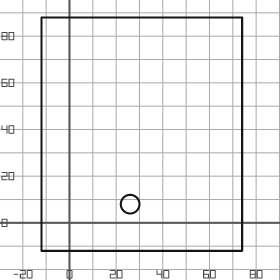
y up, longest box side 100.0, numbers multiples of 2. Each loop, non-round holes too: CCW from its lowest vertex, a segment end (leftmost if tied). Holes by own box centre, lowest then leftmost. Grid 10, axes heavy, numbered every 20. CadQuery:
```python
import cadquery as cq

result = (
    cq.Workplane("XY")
    .moveTo(-12.0, -12.0)
    .lineTo(74.0, -12.0)
    .lineTo(74.0, 88.0)
    .lineTo(-12.0, 88.0)
    .close()
    .moveTo(26.0, 8.0)
    .circle(4.0)
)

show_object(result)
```